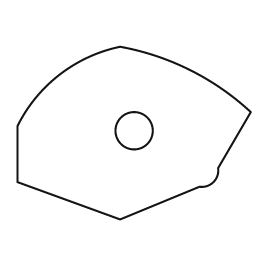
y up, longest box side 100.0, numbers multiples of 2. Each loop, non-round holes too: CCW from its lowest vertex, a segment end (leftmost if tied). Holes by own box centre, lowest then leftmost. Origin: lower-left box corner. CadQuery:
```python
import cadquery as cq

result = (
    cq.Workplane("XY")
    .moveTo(44.0, 0.0)
    .lineTo(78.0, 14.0)
    .threePointArc((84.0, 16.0), (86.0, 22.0))
    .lineTo(100.0, 46.0)
    .threePointArc((74.0, 64.0), (44.0, 74.0))
    .threePointArc((18.0, 62.0), (0.0, 40.0))
    .lineTo(0.0, 16.0)
    .close()
    .moveTo(50.0, 38.0)
    .circle(8.0)
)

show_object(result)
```